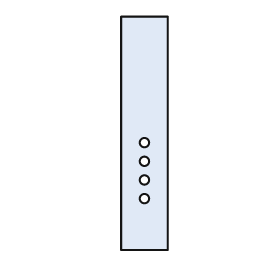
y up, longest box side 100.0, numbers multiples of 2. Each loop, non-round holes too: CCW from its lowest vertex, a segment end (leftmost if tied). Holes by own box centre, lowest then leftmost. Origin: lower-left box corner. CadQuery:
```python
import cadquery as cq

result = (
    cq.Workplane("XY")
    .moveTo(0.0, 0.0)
    .lineTo(20.0, 0.0)
    .lineTo(20.0, 100.0)
    .lineTo(0.0, 100.0)
    .close()
    .moveTo(10.0, 22.0)
    .circle(2.0)
    .moveTo(10.0, 30.0)
    .circle(2.0)
    .moveTo(10.0, 38.0)
    .circle(2.0)
    .moveTo(10.0, 46.0)
    .circle(2.0)
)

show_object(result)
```